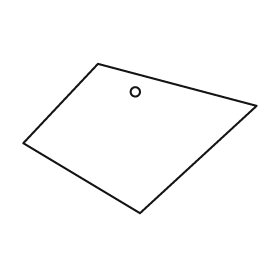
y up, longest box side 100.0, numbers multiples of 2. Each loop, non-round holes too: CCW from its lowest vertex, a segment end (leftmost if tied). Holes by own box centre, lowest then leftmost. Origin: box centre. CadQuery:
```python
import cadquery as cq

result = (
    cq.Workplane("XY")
    .moveTo(0.0, -32.0)
    .lineTo(50.0, 14.0)
    .lineTo(-18.0, 32.0)
    .lineTo(-50.0, -2.0)
    .close()
    .moveTo(-2.0, 20.0)
    .circle(2.0)
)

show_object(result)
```